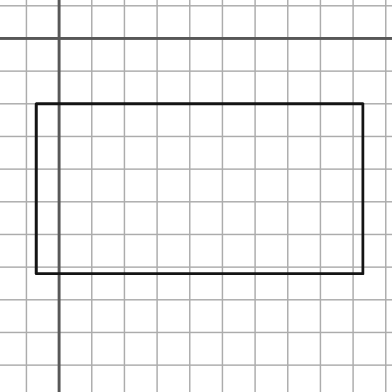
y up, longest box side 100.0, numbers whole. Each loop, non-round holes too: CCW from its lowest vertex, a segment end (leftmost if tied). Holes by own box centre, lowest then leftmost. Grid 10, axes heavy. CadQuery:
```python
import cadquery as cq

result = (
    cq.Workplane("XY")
    .moveTo(-7.0, -72.0)
    .lineTo(93.0, -72.0)
    .lineTo(93.0, -20.0)
    .lineTo(-7.0, -20.0)
    .close()
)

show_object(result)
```